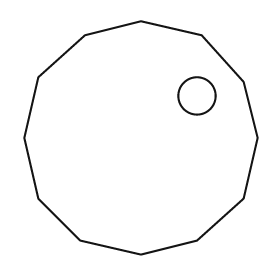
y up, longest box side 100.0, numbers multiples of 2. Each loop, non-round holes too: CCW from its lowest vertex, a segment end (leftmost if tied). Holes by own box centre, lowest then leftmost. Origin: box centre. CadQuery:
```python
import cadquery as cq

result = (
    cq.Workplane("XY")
    .moveTo(0.0, -50.0)
    .lineTo(24.0, -44.0)
    .lineTo(44.0, -26.0)
    .lineTo(50.0, 0.0)
    .lineTo(44.0, 24.0)
    .lineTo(26.0, 44.0)
    .lineTo(0.0, 50.0)
    .lineTo(-24.0, 44.0)
    .lineTo(-44.0, 26.0)
    .lineTo(-50.0, 0.0)
    .lineTo(-44.0, -26.0)
    .lineTo(-26.0, -44.0)
    .close()
    .moveTo(24.0, 18.0)
    .circle(8.0)
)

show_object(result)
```